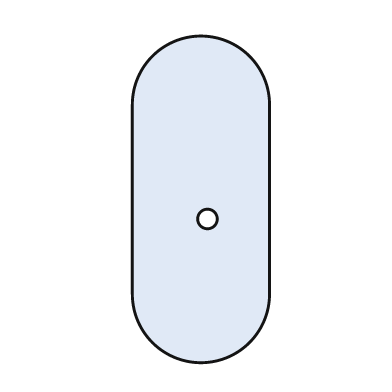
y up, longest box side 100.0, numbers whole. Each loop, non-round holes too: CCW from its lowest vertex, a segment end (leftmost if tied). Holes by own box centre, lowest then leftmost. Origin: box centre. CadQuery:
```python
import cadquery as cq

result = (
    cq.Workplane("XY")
    .moveTo(-21.0, -29.0)
    .threePointArc((0.0, -50.0), (21.0, -29.0))
    .lineTo(21.0, 29.0)
    .threePointArc((0.0, 50.0), (-21.0, 29.0))
    .close()
    .moveTo(2.0, -6.0)
    .circle(3.0)
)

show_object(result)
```